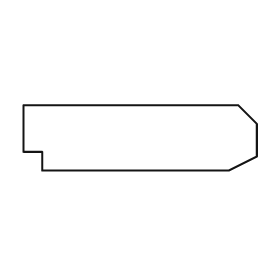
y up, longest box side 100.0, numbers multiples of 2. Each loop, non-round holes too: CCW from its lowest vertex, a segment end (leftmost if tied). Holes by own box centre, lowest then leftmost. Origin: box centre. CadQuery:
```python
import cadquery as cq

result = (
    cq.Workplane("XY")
    .moveTo(-42.0, -14.0)
    .lineTo(38.0, -14.0)
    .lineTo(50.0, -8.0)
    .lineTo(50.0, 6.0)
    .lineTo(42.0, 14.0)
    .lineTo(-50.0, 14.0)
    .lineTo(-50.0, -6.0)
    .lineTo(-42.0, -6.0)
    .close()
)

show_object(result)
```